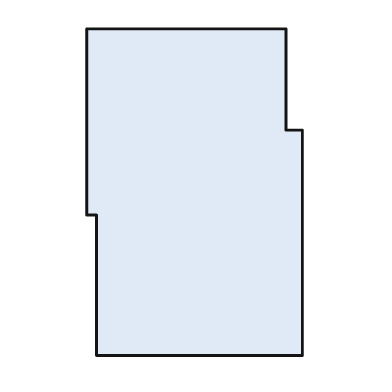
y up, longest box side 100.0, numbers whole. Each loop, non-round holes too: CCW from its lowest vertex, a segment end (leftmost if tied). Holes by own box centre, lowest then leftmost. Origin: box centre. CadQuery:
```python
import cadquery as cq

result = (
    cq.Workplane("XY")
    .moveTo(-30.0, -50.0)
    .lineTo(33.0, -50.0)
    .lineTo(33.0, 19.0)
    .lineTo(28.0, 19.0)
    .lineTo(28.0, 50.0)
    .lineTo(-33.0, 50.0)
    .lineTo(-33.0, -7.0)
    .lineTo(-30.0, -7.0)
    .close()
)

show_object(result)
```